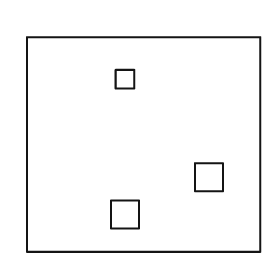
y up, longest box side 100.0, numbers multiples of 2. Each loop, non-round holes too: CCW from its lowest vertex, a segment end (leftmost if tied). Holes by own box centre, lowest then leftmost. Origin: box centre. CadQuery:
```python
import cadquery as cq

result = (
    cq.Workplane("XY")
    .moveTo(-50.0, -46.0)
    .lineTo(50.0, -46.0)
    .lineTo(50.0, 46.0)
    .lineTo(-50.0, 46.0)
    .close()
    .moveTo(-14.0, -36.0)
    .lineTo(-2.0, -36.0)
    .lineTo(-2.0, -24.0)
    .lineTo(-14.0, -24.0)
    .close()
    .moveTo(22.0, -20.0)
    .lineTo(34.0, -20.0)
    .lineTo(34.0, -8.0)
    .lineTo(22.0, -8.0)
    .close()
    .moveTo(-12.0, 24.0)
    .lineTo(-4.0, 24.0)
    .lineTo(-4.0, 32.0)
    .lineTo(-12.0, 32.0)
    .close()
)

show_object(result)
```